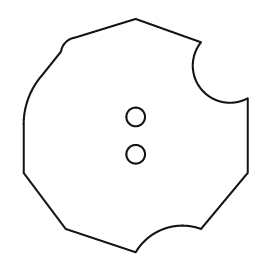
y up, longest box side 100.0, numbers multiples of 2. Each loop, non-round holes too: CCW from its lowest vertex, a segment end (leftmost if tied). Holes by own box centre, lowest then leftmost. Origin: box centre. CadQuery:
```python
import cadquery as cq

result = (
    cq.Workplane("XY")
    .moveTo(0.0, -50.0)
    .threePointArc((12.0, -40.0), (28.0, -40.0))
    .lineTo(48.0, -16.0)
    .lineTo(48.0, 16.0)
    .threePointArc((28.0, 20.0), (28.0, 40.0))
    .lineTo(0.0, 50.0)
    .lineTo(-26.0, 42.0)
    .threePointArc((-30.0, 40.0), (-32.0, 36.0))
    .lineTo(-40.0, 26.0)
    .threePointArc((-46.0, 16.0), (-48.0, 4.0))
    .lineTo(-48.0, -16.0)
    .lineTo(-30.0, -40.0)
    .close()
    .moveTo(0.0, -8.0)
    .circle(4.0)
    .moveTo(0.0, 8.0)
    .circle(4.0)
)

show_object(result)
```